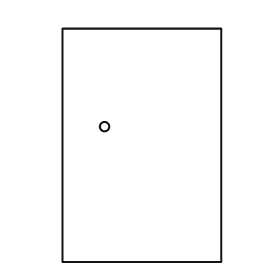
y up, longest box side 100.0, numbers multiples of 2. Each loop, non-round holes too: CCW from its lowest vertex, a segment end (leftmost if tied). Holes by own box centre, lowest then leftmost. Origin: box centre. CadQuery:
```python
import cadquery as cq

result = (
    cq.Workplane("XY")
    .moveTo(-34.0, -50.0)
    .lineTo(34.0, -50.0)
    .lineTo(34.0, 50.0)
    .lineTo(-34.0, 50.0)
    .close()
    .moveTo(-16.0, 8.0)
    .circle(2.0)
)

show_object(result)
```